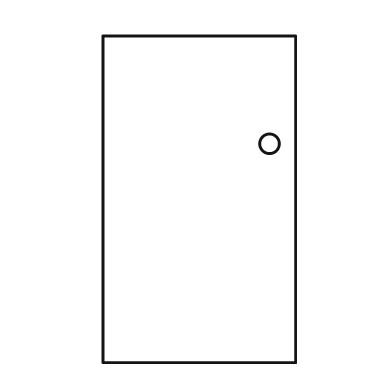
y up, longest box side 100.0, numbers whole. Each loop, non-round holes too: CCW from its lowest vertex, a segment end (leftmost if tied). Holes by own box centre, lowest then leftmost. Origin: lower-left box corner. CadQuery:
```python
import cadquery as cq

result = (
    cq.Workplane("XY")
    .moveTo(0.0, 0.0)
    .lineTo(59.0, 0.0)
    .lineTo(59.0, 100.0)
    .lineTo(0.0, 100.0)
    .close()
    .moveTo(51.0, 67.0)
    .circle(3.0)
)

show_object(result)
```